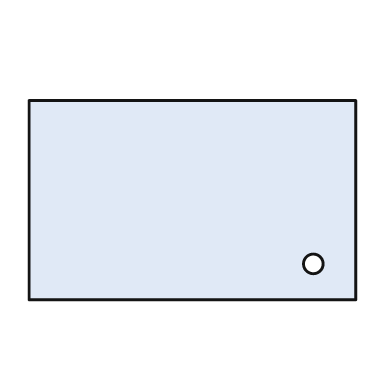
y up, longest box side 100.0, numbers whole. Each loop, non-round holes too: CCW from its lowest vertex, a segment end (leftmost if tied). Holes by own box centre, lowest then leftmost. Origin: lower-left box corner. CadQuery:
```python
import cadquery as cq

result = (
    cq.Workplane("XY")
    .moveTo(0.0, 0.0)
    .lineTo(100.0, 0.0)
    .lineTo(100.0, 61.0)
    .lineTo(0.0, 61.0)
    .close()
    .moveTo(87.0, 11.0)
    .circle(3.0)
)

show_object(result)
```